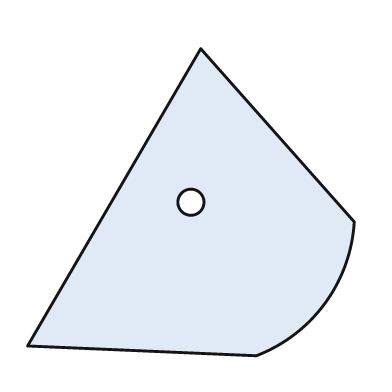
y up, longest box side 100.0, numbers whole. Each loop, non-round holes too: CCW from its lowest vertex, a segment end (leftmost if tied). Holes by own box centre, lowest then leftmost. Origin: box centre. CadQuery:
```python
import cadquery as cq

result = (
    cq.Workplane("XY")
    .moveTo(20.0, -47.0)
    .threePointArc((41.0, -31.0), (50.0, -6.0))
    .lineTo(3.0, 47.0)
    .lineTo(-50.0, -44.0)
    .close()
    .moveTo(0.0, 0.0)
    .circle(4.0)
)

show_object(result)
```